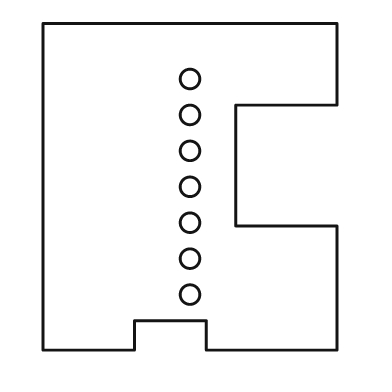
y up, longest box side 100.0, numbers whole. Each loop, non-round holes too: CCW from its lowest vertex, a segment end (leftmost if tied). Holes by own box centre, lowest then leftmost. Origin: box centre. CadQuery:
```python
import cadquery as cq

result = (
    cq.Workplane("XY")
    .moveTo(-45.0, -50.0)
    .lineTo(-17.0, -50.0)
    .lineTo(-17.0, -41.0)
    .lineTo(5.0, -41.0)
    .lineTo(5.0, -50.0)
    .lineTo(45.0, -50.0)
    .lineTo(45.0, -12.0)
    .lineTo(14.0, -12.0)
    .lineTo(14.0, 25.0)
    .lineTo(45.0, 25.0)
    .lineTo(45.0, 50.0)
    .lineTo(-45.0, 50.0)
    .close()
    .moveTo(0.0, -33.0)
    .circle(3.0)
    .moveTo(0.0, -22.0)
    .circle(3.0)
    .moveTo(0.0, -11.0)
    .circle(3.0)
    .moveTo(0.0, 0.0)
    .circle(3.0)
    .moveTo(0.0, 11.0)
    .circle(3.0)
    .moveTo(0.0, 22.0)
    .circle(3.0)
    .moveTo(0.0, 33.0)
    .circle(3.0)
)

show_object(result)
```